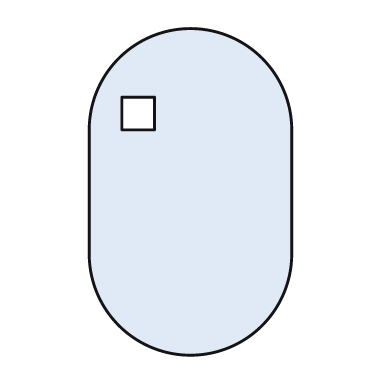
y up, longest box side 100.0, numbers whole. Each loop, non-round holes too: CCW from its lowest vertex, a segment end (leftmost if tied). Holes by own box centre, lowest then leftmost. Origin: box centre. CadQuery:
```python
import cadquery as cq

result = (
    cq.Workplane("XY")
    .moveTo(-31.0, -19.0)
    .threePointArc((0.0, -50.0), (31.0, -19.0))
    .lineTo(31.0, 19.0)
    .threePointArc((0.0, 50.0), (-31.0, 19.0))
    .close()
    .moveTo(-21.0, 19.0)
    .lineTo(-11.0, 19.0)
    .lineTo(-11.0, 29.0)
    .lineTo(-21.0, 29.0)
    .close()
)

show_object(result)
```